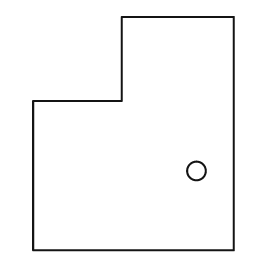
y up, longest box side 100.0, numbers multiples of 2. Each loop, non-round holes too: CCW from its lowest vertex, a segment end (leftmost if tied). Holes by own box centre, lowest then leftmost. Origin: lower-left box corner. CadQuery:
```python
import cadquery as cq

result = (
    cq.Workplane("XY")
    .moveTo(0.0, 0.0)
    .lineTo(86.0, 0.0)
    .lineTo(86.0, 100.0)
    .lineTo(38.0, 100.0)
    .lineTo(38.0, 64.0)
    .lineTo(0.0, 64.0)
    .close()
    .moveTo(70.0, 34.0)
    .circle(4.0)
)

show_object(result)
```